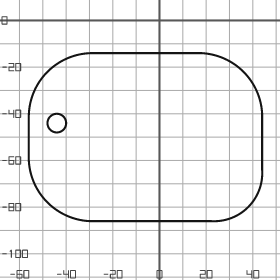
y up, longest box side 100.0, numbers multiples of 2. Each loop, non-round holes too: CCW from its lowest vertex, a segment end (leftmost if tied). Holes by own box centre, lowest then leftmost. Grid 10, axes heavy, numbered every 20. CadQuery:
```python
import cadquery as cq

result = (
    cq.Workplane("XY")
    .moveTo(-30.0, -86.0)
    .lineTo(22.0, -86.0)
    .threePointArc((38.0, -80.0), (44.0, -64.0))
    .lineTo(44.0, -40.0)
    .threePointArc((36.0, -22.0), (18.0, -14.0))
    .lineTo(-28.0, -14.0)
    .threePointArc((-48.0, -22.0), (-56.0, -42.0))
    .lineTo(-56.0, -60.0)
    .threePointArc((-48.0, -78.0), (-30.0, -86.0))
    .close()
    .moveTo(-44.0, -44.0)
    .circle(4.0)
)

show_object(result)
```